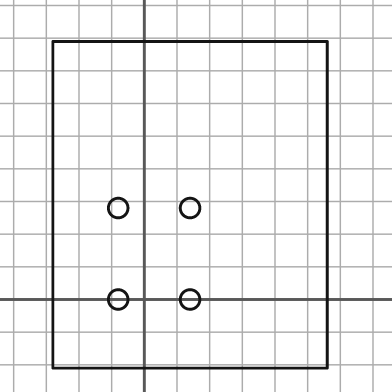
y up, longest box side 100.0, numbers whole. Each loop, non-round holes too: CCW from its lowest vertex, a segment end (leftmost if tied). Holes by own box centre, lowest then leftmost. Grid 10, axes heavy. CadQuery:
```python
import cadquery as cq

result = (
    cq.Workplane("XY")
    .moveTo(-28.0, -21.0)
    .lineTo(56.0, -21.0)
    .lineTo(56.0, 79.0)
    .lineTo(-28.0, 79.0)
    .close()
    .moveTo(-8.0, 0.0)
    .circle(3.0)
    .moveTo(14.0, 0.0)
    .circle(3.0)
    .moveTo(-8.0, 28.0)
    .circle(3.0)
    .moveTo(14.0, 28.0)
    .circle(3.0)
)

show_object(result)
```